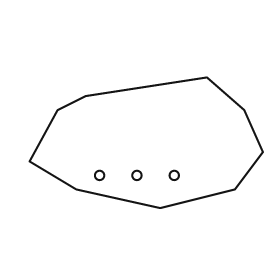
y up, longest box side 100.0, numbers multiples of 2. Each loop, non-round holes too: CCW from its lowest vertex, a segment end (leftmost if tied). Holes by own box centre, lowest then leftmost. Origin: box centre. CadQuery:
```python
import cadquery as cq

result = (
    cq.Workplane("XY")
    .moveTo(6.0, -28.0)
    .lineTo(38.0, -20.0)
    .lineTo(50.0, -4.0)
    .lineTo(42.0, 14.0)
    .lineTo(26.0, 28.0)
    .lineTo(-26.0, 20.0)
    .lineTo(-38.0, 14.0)
    .lineTo(-50.0, -8.0)
    .lineTo(-30.0, -20.0)
    .close()
    .moveTo(-20.0, -14.0)
    .circle(2.0)
    .moveTo(-4.0, -14.0)
    .circle(2.0)
    .moveTo(12.0, -14.0)
    .circle(2.0)
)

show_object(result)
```